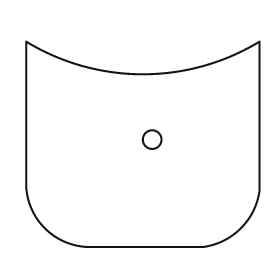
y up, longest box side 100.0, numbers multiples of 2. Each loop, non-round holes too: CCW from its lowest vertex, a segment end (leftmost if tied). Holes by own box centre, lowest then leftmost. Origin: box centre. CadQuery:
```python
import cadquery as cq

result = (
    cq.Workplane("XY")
    .moveTo(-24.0, -44.0)
    .lineTo(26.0, -44.0)
    .threePointArc((42.0, -36.0), (50.0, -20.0))
    .lineTo(50.0, 44.0)
    .threePointArc((0.0, 30.0), (-50.0, 44.0))
    .lineTo(-50.0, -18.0)
    .threePointArc((-42.0, -36.0), (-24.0, -44.0))
    .close()
    .moveTo(4.0, 2.0)
    .circle(4.0)
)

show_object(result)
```